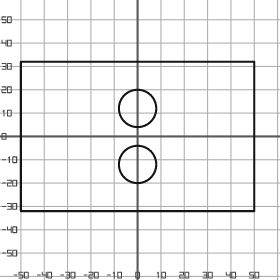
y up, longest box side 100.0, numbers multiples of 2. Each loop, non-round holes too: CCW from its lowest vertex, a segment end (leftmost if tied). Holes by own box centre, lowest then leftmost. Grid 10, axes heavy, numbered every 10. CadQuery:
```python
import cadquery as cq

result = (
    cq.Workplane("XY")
    .moveTo(-50.0, -32.0)
    .lineTo(50.0, -32.0)
    .lineTo(50.0, 32.0)
    .lineTo(-50.0, 32.0)
    .close()
    .moveTo(0.0, -12.0)
    .circle(8.0)
    .moveTo(0.0, 12.0)
    .circle(8.0)
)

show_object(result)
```